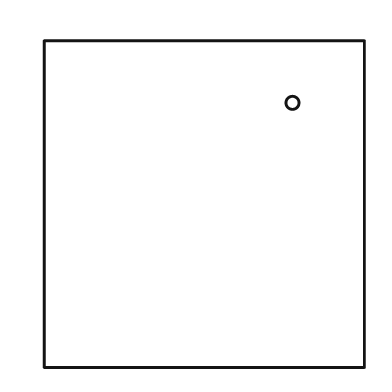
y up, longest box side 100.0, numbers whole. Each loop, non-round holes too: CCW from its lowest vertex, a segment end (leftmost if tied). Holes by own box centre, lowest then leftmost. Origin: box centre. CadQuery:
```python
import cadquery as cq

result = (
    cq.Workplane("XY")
    .moveTo(-49.0, -50.0)
    .lineTo(49.0, -50.0)
    .lineTo(49.0, 50.0)
    .lineTo(-49.0, 50.0)
    .close()
    .moveTo(27.0, 31.0)
    .circle(2.0)
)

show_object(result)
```